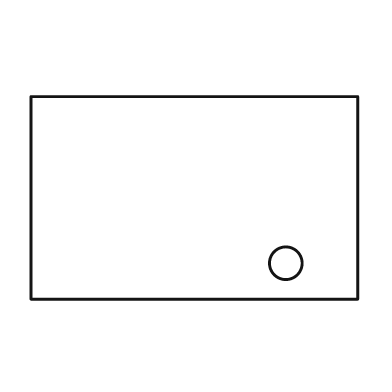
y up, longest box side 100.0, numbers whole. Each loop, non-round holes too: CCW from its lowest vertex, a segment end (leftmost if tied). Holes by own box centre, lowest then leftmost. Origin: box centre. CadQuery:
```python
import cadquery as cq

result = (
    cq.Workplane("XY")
    .moveTo(-50.0, -31.0)
    .lineTo(50.0, -31.0)
    .lineTo(50.0, 31.0)
    .lineTo(-50.0, 31.0)
    .close()
    .moveTo(28.0, -20.0)
    .circle(5.0)
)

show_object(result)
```